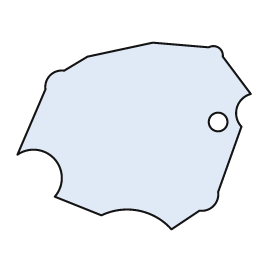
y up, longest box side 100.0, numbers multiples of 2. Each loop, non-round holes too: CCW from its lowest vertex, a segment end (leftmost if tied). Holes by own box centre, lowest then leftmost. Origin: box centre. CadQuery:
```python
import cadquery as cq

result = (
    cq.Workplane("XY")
    .moveTo(16.0, -40.0)
    .lineTo(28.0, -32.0)
    .threePointArc((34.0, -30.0), (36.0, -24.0))
    .lineTo(46.0, 4.0)
    .threePointArc((44.0, 12.0), (50.0, 18.0))
    .lineTo(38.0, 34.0)
    .threePointArc((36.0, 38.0), (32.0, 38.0))
    .lineTo(8.0, 40.0)
    .lineTo(-20.0, 34.0)
    .lineTo(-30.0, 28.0)
    .threePointArc((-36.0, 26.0), (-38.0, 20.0))
    .lineTo(-50.0, -8.0)
    .threePointArc((-34.0, -10.0), (-34.0, -26.0))
    .lineTo(-14.0, -34.0)
    .threePointArc((2.0, -32.0), (16.0, -40.0))
    .close()
    .moveTo(36.0, 6.0)
    .circle(4.0)
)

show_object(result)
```